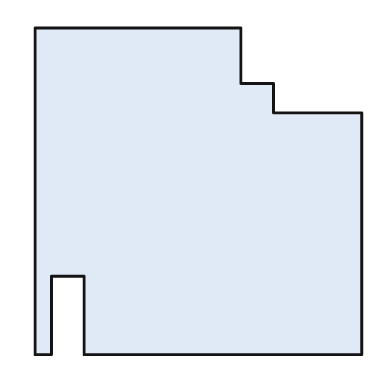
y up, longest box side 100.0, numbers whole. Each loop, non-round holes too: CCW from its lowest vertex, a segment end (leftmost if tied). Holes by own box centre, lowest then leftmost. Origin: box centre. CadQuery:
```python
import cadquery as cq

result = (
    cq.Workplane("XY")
    .moveTo(-50.0, -50.0)
    .lineTo(-45.0, -50.0)
    .lineTo(-45.0, -26.0)
    .lineTo(-35.0, -26.0)
    .lineTo(-35.0, -50.0)
    .lineTo(50.0, -50.0)
    .lineTo(50.0, 24.0)
    .lineTo(23.0, 24.0)
    .lineTo(23.0, 33.0)
    .lineTo(13.0, 33.0)
    .lineTo(13.0, 50.0)
    .lineTo(-50.0, 50.0)
    .close()
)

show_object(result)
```